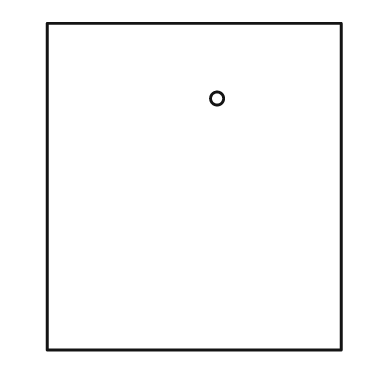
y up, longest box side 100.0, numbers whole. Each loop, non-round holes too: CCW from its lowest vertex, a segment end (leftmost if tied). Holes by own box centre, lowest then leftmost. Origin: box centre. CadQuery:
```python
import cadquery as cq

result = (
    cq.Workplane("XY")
    .moveTo(-45.0, -50.0)
    .lineTo(45.0, -50.0)
    .lineTo(45.0, 50.0)
    .lineTo(-45.0, 50.0)
    .close()
    .moveTo(7.0, 27.0)
    .circle(2.0)
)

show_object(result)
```